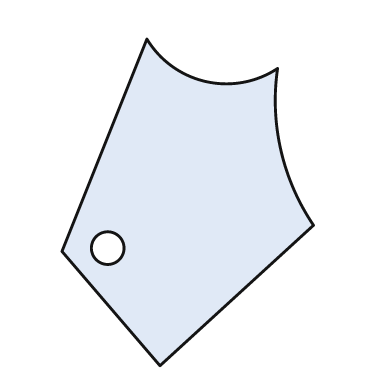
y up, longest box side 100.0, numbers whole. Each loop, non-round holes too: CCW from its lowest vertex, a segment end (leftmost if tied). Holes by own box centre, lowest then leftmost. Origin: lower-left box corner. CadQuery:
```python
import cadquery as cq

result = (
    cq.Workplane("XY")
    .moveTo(30.0, 0.0)
    .lineTo(77.0, 43.0)
    .threePointArc((67.0, 66.0), (66.0, 91.0))
    .threePointArc((44.0, 87.0), (26.0, 100.0))
    .lineTo(0.0, 35.0)
    .close()
    .moveTo(14.0, 36.0)
    .circle(5.0)
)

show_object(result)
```